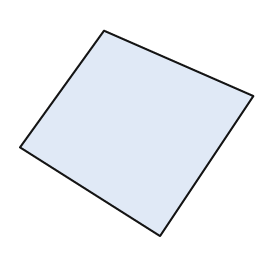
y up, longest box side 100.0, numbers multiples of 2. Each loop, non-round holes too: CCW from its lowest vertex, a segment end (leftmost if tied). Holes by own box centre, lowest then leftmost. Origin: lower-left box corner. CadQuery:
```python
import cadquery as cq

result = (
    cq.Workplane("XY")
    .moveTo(60.0, 0.0)
    .lineTo(100.0, 60.0)
    .lineTo(36.0, 88.0)
    .lineTo(0.0, 38.0)
    .close()
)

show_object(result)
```